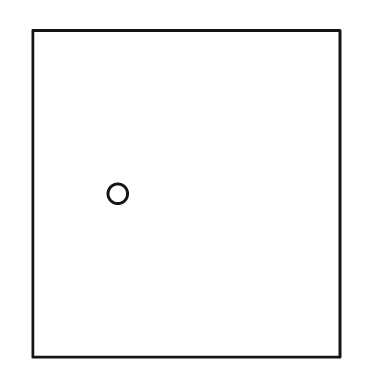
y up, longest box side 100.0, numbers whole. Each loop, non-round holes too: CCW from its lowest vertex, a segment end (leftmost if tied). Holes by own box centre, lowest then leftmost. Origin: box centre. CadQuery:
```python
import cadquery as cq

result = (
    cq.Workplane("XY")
    .moveTo(-47.0, -50.0)
    .lineTo(47.0, -50.0)
    .lineTo(47.0, 50.0)
    .lineTo(-47.0, 50.0)
    .close()
    .moveTo(-21.0, 0.0)
    .circle(3.0)
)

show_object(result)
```